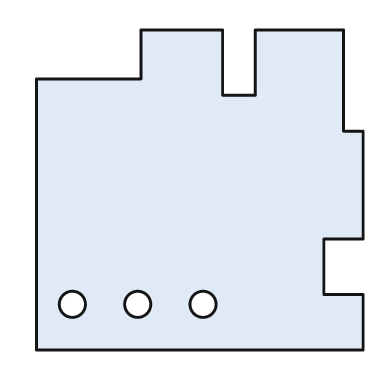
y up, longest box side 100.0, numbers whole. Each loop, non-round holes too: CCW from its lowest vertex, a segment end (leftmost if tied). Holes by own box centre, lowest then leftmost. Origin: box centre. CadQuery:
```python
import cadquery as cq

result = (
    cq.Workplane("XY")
    .moveTo(-50.0, -49.0)
    .lineTo(50.0, -49.0)
    .lineTo(50.0, -32.0)
    .lineTo(38.0, -32.0)
    .lineTo(38.0, -15.0)
    .lineTo(50.0, -15.0)
    .lineTo(50.0, 18.0)
    .lineTo(44.0, 18.0)
    .lineTo(44.0, 49.0)
    .lineTo(17.0, 49.0)
    .lineTo(17.0, 29.0)
    .lineTo(7.0, 29.0)
    .lineTo(7.0, 49.0)
    .lineTo(-18.0, 49.0)
    .lineTo(-18.0, 34.0)
    .lineTo(-50.0, 34.0)
    .close()
    .moveTo(-39.0, -35.0)
    .circle(4.0)
    .moveTo(-19.0, -35.0)
    .circle(4.0)
    .moveTo(1.0, -35.0)
    .circle(4.0)
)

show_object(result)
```